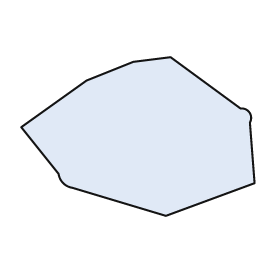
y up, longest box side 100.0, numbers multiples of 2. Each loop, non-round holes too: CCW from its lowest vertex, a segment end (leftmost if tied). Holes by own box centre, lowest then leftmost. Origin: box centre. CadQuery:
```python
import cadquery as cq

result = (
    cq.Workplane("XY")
    .moveTo(12.0, -34.0)
    .lineTo(50.0, -20.0)
    .lineTo(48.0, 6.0)
    .threePointArc((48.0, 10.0), (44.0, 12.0))
    .lineTo(14.0, 34.0)
    .lineTo(-2.0, 32.0)
    .lineTo(-22.0, 24.0)
    .lineTo(-50.0, 4.0)
    .lineTo(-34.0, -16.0)
    .threePointArc((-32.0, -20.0), (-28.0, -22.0))
    .close()
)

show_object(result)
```